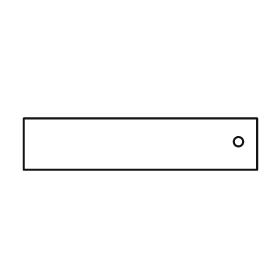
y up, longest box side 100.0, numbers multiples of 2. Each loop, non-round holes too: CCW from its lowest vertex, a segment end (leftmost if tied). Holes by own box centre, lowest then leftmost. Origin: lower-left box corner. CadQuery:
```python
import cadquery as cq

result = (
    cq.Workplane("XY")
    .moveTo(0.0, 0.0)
    .lineTo(100.0, 0.0)
    .lineTo(100.0, 22.0)
    .lineTo(0.0, 22.0)
    .close()
    .moveTo(92.0, 12.0)
    .circle(2.0)
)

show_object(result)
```